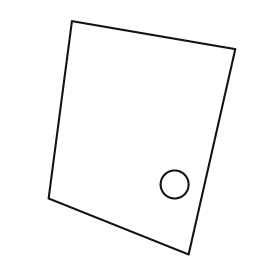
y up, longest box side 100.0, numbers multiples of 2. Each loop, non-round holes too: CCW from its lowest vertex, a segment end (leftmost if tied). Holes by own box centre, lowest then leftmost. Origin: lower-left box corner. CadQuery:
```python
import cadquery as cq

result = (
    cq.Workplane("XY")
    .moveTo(60.0, 0.0)
    .lineTo(80.0, 88.0)
    .lineTo(10.0, 100.0)
    .lineTo(0.0, 24.0)
    .close()
    .moveTo(54.0, 30.0)
    .circle(6.0)
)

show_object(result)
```